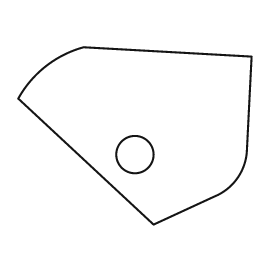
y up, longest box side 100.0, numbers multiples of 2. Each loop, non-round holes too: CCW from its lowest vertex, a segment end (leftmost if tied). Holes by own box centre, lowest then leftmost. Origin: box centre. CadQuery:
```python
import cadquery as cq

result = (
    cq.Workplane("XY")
    .moveTo(8.0, -38.0)
    .lineTo(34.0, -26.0)
    .threePointArc((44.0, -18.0), (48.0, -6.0))
    .lineTo(50.0, 34.0)
    .lineTo(-22.0, 38.0)
    .threePointArc((-38.0, 30.0), (-50.0, 16.0))
    .close()
    .moveTo(0.0, -8.0)
    .circle(8.0)
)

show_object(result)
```